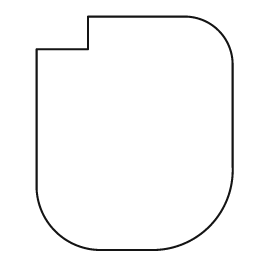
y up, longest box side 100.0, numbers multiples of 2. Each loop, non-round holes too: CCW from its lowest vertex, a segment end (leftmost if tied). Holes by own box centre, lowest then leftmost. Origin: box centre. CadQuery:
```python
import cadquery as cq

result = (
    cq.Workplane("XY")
    .moveTo(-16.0, -50.0)
    .lineTo(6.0, -50.0)
    .threePointArc((32.0, -40.0), (42.0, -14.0))
    .lineTo(42.0, 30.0)
    .threePointArc((36.0, 44.0), (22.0, 50.0))
    .lineTo(-20.0, 50.0)
    .lineTo(-20.0, 36.0)
    .lineTo(-42.0, 36.0)
    .lineTo(-42.0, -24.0)
    .threePointArc((-34.0, -42.0), (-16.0, -50.0))
    .close()
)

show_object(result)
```